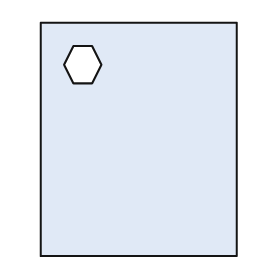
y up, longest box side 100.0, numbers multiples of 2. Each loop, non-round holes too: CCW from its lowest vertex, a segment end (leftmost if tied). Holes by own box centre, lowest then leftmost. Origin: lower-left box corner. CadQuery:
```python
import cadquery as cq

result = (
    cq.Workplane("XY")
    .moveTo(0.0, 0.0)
    .lineTo(84.0, 0.0)
    .lineTo(84.0, 100.0)
    .lineTo(0.0, 100.0)
    .close()
    .moveTo(14.0, 74.0)
    .lineTo(22.0, 74.0)
    .lineTo(26.0, 82.0)
    .lineTo(22.0, 90.0)
    .lineTo(14.0, 90.0)
    .lineTo(10.0, 82.0)
    .close()
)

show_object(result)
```